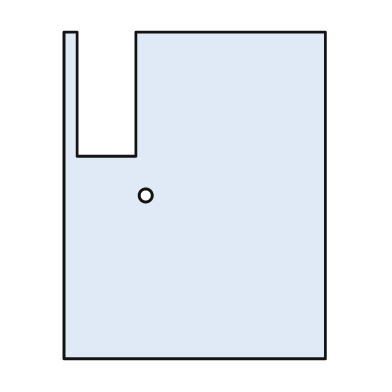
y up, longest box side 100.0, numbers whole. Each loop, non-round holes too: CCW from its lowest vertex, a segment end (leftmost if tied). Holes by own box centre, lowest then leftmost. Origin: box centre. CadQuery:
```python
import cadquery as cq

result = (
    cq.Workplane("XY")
    .moveTo(-40.0, -50.0)
    .lineTo(40.0, -50.0)
    .lineTo(40.0, 50.0)
    .lineTo(-18.0, 50.0)
    .lineTo(-18.0, 12.0)
    .lineTo(-36.0, 12.0)
    .lineTo(-36.0, 50.0)
    .lineTo(-40.0, 50.0)
    .close()
    .moveTo(-15.0, 0.0)
    .circle(2.0)
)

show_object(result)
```